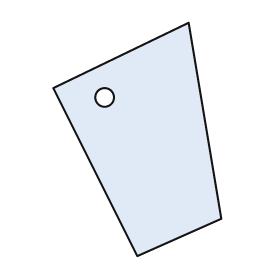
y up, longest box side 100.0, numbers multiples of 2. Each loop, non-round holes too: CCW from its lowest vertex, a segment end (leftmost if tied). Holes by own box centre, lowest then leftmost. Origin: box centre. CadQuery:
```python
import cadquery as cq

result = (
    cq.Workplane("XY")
    .moveTo(0.0, -50.0)
    .lineTo(36.0, -34.0)
    .lineTo(22.0, 50.0)
    .lineTo(-36.0, 22.0)
    .close()
    .moveTo(-14.0, 18.0)
    .circle(4.0)
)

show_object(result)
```